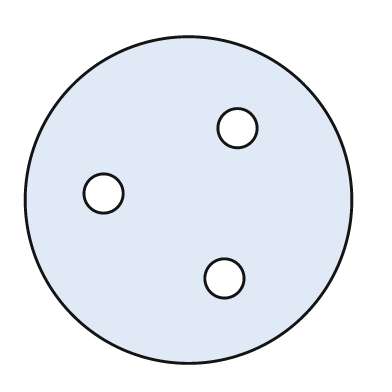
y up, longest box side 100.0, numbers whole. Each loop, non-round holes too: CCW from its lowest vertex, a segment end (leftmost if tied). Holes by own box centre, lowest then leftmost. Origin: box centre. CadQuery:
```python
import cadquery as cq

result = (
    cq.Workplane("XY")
    .moveTo(0.0, 0.0)
    .circle(50.0)
    .moveTo(11.0, -24.0)
    .circle(6.0)
    .moveTo(-26.0, 2.0)
    .circle(6.0)
    .moveTo(15.0, 22.0)
    .circle(6.0)
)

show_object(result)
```